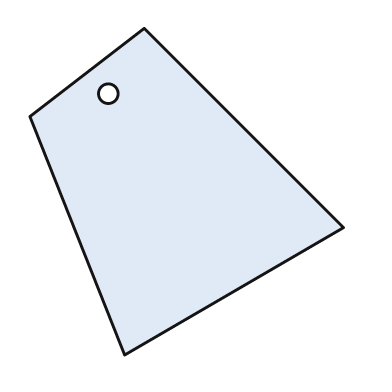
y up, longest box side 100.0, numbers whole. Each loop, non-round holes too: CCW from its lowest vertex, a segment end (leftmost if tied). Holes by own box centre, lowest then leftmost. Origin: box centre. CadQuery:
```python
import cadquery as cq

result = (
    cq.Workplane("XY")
    .moveTo(-19.0, -50.0)
    .lineTo(48.0, -11.0)
    .lineTo(-13.0, 50.0)
    .lineTo(-48.0, 23.0)
    .close()
    .moveTo(-24.0, 30.0)
    .circle(3.0)
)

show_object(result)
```